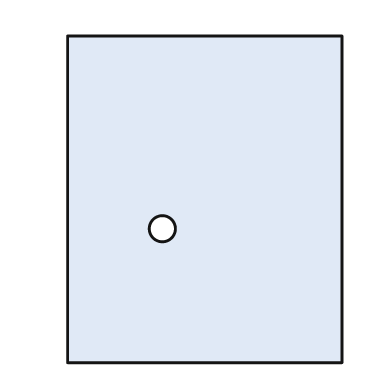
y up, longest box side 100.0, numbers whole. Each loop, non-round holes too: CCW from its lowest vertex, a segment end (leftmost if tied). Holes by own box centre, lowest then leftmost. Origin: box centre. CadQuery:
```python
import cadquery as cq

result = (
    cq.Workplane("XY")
    .moveTo(-42.0, -50.0)
    .lineTo(42.0, -50.0)
    .lineTo(42.0, 50.0)
    .lineTo(-42.0, 50.0)
    .close()
    .moveTo(-13.0, -9.0)
    .circle(4.0)
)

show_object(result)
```